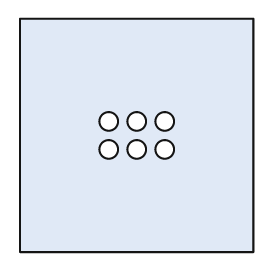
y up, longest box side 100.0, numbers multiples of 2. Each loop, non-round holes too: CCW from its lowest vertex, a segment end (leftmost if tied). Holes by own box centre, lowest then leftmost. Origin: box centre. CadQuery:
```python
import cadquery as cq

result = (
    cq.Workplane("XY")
    .moveTo(-50.0, -50.0)
    .lineTo(50.0, -50.0)
    .lineTo(50.0, 50.0)
    .lineTo(-50.0, 50.0)
    .close()
    .moveTo(-12.0, -6.0)
    .circle(4.0)
    .moveTo(0.0, -6.0)
    .circle(4.0)
    .moveTo(12.0, -6.0)
    .circle(4.0)
    .moveTo(-12.0, 6.0)
    .circle(4.0)
    .moveTo(0.0, 6.0)
    .circle(4.0)
    .moveTo(12.0, 6.0)
    .circle(4.0)
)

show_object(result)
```